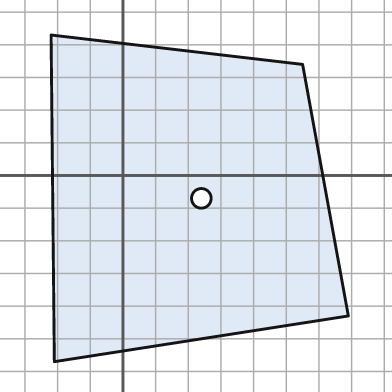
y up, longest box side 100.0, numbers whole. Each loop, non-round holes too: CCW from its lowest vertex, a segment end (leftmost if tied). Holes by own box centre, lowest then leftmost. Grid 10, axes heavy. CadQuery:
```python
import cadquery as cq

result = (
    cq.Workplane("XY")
    .moveTo(-21.0, -57.0)
    .lineTo(69.0, -43.0)
    .lineTo(55.0, 34.0)
    .lineTo(-22.0, 43.0)
    .close()
    .moveTo(24.0, -7.0)
    .circle(3.0)
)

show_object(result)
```